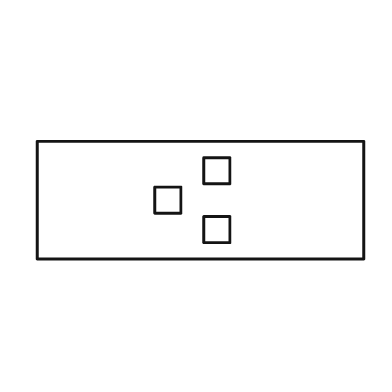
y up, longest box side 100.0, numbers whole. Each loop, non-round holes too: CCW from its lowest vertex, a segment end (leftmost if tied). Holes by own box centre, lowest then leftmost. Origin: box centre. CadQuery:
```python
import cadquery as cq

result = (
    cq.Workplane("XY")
    .moveTo(-50.0, -18.0)
    .lineTo(50.0, -18.0)
    .lineTo(50.0, 18.0)
    .lineTo(-50.0, 18.0)
    .close()
    .moveTo(1.0, -13.0)
    .lineTo(9.0, -13.0)
    .lineTo(9.0, -5.0)
    .lineTo(1.0, -5.0)
    .close()
    .moveTo(-14.0, -4.0)
    .lineTo(-6.0, -4.0)
    .lineTo(-6.0, 4.0)
    .lineTo(-14.0, 4.0)
    .close()
    .moveTo(1.0, 5.0)
    .lineTo(9.0, 5.0)
    .lineTo(9.0, 13.0)
    .lineTo(1.0, 13.0)
    .close()
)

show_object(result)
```